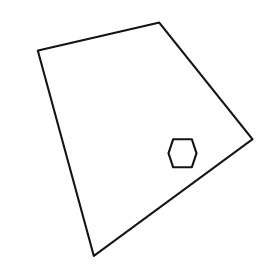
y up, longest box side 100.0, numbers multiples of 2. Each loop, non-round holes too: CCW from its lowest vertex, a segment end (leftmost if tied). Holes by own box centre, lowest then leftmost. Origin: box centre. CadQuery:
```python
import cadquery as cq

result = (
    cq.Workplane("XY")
    .moveTo(-22.0, -50.0)
    .lineTo(46.0, 0.0)
    .lineTo(6.0, 50.0)
    .lineTo(-46.0, 38.0)
    .close()
    .moveTo(12.0, -12.0)
    .lineTo(20.0, -12.0)
    .lineTo(22.0, -6.0)
    .lineTo(20.0, 0.0)
    .lineTo(12.0, 0.0)
    .lineTo(10.0, -6.0)
    .close()
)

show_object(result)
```